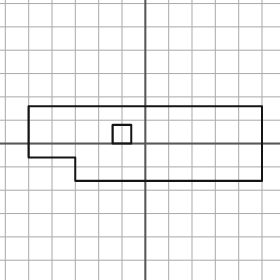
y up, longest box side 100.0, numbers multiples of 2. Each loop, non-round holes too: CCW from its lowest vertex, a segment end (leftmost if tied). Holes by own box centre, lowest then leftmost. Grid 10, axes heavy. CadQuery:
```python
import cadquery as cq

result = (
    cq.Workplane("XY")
    .moveTo(-30.0, -16.0)
    .lineTo(50.0, -16.0)
    .lineTo(50.0, 16.0)
    .lineTo(-50.0, 16.0)
    .lineTo(-50.0, -6.0)
    .lineTo(-30.0, -6.0)
    .close()
    .moveTo(-14.0, 0.0)
    .lineTo(-6.0, 0.0)
    .lineTo(-6.0, 8.0)
    .lineTo(-14.0, 8.0)
    .close()
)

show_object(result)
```